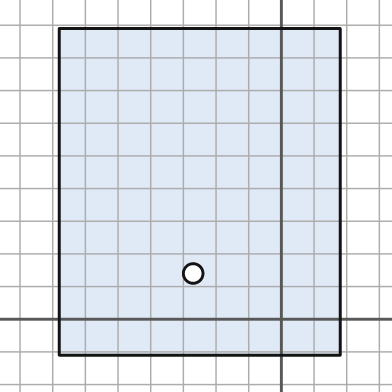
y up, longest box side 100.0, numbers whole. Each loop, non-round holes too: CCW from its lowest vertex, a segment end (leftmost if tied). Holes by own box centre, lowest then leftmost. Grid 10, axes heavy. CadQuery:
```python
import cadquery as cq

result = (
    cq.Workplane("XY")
    .moveTo(-68.0, -11.0)
    .lineTo(18.0, -11.0)
    .lineTo(18.0, 89.0)
    .lineTo(-68.0, 89.0)
    .close()
    .moveTo(-27.0, 14.0)
    .circle(3.0)
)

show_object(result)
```